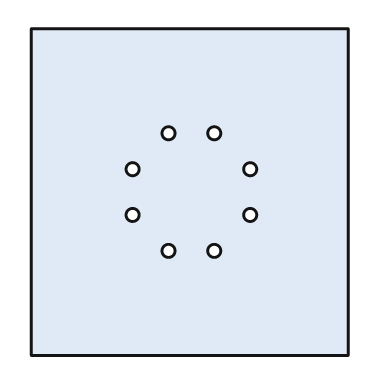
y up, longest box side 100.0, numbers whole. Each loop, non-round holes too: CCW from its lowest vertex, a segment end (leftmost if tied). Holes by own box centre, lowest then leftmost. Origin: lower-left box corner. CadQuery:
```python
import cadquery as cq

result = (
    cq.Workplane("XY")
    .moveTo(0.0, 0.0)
    .lineTo(97.0, 0.0)
    .lineTo(97.0, 100.0)
    .lineTo(0.0, 100.0)
    .close()
    .moveTo(42.0, 32.0)
    .circle(2.0)
    .moveTo(56.0, 32.0)
    .circle(2.0)
    .moveTo(31.0, 43.0)
    .circle(2.0)
    .moveTo(67.0, 43.0)
    .circle(2.0)
    .moveTo(31.0, 57.0)
    .circle(2.0)
    .moveTo(67.0, 57.0)
    .circle(2.0)
    .moveTo(42.0, 68.0)
    .circle(2.0)
    .moveTo(56.0, 68.0)
    .circle(2.0)
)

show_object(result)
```